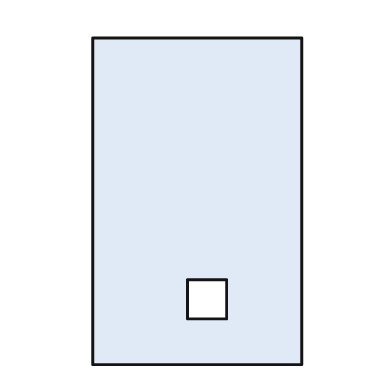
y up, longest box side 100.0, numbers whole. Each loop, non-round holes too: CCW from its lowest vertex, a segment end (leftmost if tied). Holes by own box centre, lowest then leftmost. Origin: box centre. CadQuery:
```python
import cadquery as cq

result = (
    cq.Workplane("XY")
    .moveTo(-32.0, -50.0)
    .lineTo(32.0, -50.0)
    .lineTo(32.0, 50.0)
    .lineTo(-32.0, 50.0)
    .close()
    .moveTo(-3.0, -36.0)
    .lineTo(9.0, -36.0)
    .lineTo(9.0, -24.0)
    .lineTo(-3.0, -24.0)
    .close()
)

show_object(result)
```